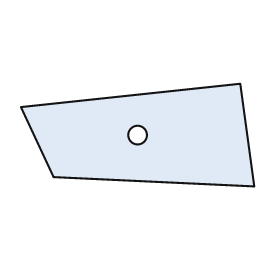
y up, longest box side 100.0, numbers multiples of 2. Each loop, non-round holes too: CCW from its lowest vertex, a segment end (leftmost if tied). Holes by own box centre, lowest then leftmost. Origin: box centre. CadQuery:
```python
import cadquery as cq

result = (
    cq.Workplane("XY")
    .moveTo(50.0, -22.0)
    .lineTo(44.0, 22.0)
    .lineTo(-50.0, 12.0)
    .lineTo(-36.0, -18.0)
    .close()
    .moveTo(0.0, 0.0)
    .circle(4.0)
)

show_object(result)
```